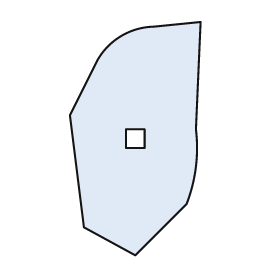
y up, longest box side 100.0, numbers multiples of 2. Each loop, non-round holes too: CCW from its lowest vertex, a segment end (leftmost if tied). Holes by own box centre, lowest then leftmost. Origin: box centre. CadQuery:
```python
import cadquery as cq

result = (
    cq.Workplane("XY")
    .moveTo(0.0, -50.0)
    .lineTo(22.0, -28.0)
    .threePointArc((26.0, -12.0), (26.0, 4.0))
    .lineTo(28.0, 50.0)
    .lineTo(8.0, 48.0)
    .threePointArc((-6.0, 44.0), (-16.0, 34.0))
    .lineTo(-28.0, 10.0)
    .lineTo(-22.0, -38.0)
    .close()
    .moveTo(-4.0, -4.0)
    .lineTo(4.0, -4.0)
    .lineTo(4.0, 4.0)
    .lineTo(-4.0, 4.0)
    .close()
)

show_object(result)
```